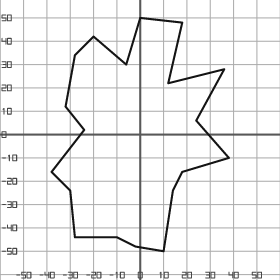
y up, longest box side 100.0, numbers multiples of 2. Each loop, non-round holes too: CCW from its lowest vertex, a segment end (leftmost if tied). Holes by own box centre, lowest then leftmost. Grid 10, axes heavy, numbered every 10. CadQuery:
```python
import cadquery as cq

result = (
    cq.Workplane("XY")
    .moveTo(10.0, -50.0)
    .lineTo(14.0, -24.0)
    .lineTo(18.0, -16.0)
    .lineTo(38.0, -10.0)
    .lineTo(24.0, 6.0)
    .lineTo(36.0, 28.0)
    .lineTo(12.0, 22.0)
    .lineTo(18.0, 48.0)
    .lineTo(0.0, 50.0)
    .lineTo(-6.0, 30.0)
    .lineTo(-20.0, 42.0)
    .lineTo(-28.0, 34.0)
    .lineTo(-32.0, 12.0)
    .lineTo(-24.0, 2.0)
    .lineTo(-38.0, -16.0)
    .lineTo(-30.0, -24.0)
    .lineTo(-28.0, -44.0)
    .lineTo(-10.0, -44.0)
    .lineTo(-2.0, -48.0)
    .close()
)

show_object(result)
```